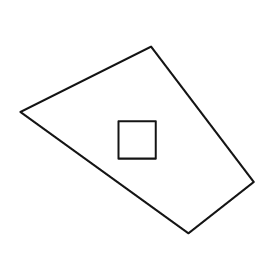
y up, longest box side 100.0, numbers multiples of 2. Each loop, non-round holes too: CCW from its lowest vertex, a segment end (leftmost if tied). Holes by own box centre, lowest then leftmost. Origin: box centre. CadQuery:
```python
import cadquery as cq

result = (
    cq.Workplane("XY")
    .moveTo(22.0, -40.0)
    .lineTo(50.0, -18.0)
    .lineTo(6.0, 40.0)
    .lineTo(-50.0, 12.0)
    .close()
    .moveTo(-8.0, -8.0)
    .lineTo(8.0, -8.0)
    .lineTo(8.0, 8.0)
    .lineTo(-8.0, 8.0)
    .close()
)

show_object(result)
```